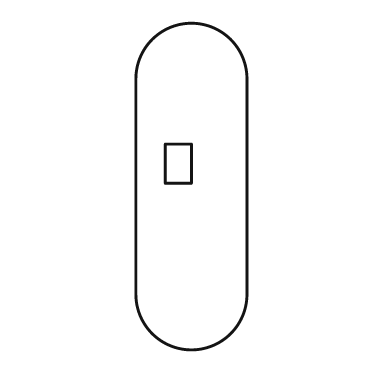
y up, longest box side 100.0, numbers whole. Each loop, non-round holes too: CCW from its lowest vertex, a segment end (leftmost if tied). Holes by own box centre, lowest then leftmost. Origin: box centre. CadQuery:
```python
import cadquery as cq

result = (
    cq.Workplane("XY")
    .moveTo(-17.0, -33.0)
    .threePointArc((0.0, -50.0), (17.0, -33.0))
    .lineTo(17.0, 33.0)
    .threePointArc((0.0, 50.0), (-17.0, 33.0))
    .close()
    .moveTo(-8.0, 1.0)
    .lineTo(0.0, 1.0)
    .lineTo(0.0, 13.0)
    .lineTo(-8.0, 13.0)
    .close()
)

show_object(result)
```